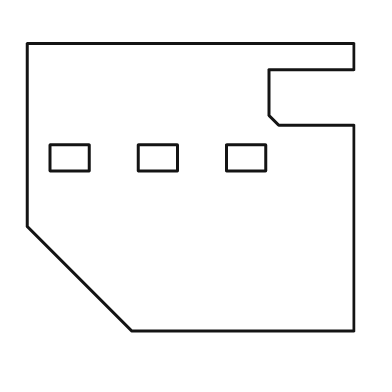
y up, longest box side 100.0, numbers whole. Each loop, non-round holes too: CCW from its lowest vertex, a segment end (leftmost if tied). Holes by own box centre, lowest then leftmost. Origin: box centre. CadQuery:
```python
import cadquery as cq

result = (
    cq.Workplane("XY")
    .moveTo(-18.0, -44.0)
    .lineTo(50.0, -44.0)
    .lineTo(50.0, 19.0)
    .lineTo(27.0, 19.0)
    .lineTo(24.0, 22.0)
    .lineTo(24.0, 36.0)
    .lineTo(50.0, 36.0)
    .lineTo(50.0, 44.0)
    .lineTo(-50.0, 44.0)
    .lineTo(-50.0, -12.0)
    .close()
    .moveTo(-43.0, 5.0)
    .lineTo(-31.0, 5.0)
    .lineTo(-31.0, 13.0)
    .lineTo(-43.0, 13.0)
    .close()
    .moveTo(-16.0, 5.0)
    .lineTo(-4.0, 5.0)
    .lineTo(-4.0, 13.0)
    .lineTo(-16.0, 13.0)
    .close()
    .moveTo(11.0, 5.0)
    .lineTo(23.0, 5.0)
    .lineTo(23.0, 13.0)
    .lineTo(11.0, 13.0)
    .close()
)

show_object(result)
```